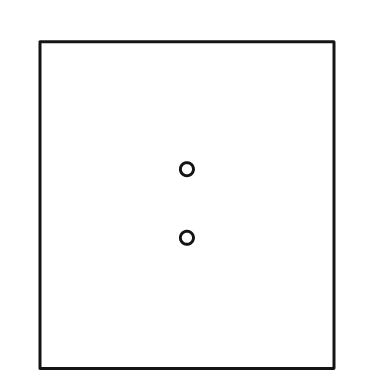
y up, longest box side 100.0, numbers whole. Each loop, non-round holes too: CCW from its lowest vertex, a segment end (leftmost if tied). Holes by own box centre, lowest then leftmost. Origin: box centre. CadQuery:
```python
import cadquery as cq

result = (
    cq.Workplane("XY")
    .moveTo(-45.0, -50.0)
    .lineTo(45.0, -50.0)
    .lineTo(45.0, 50.0)
    .lineTo(-45.0, 50.0)
    .close()
    .moveTo(0.0, -10.0)
    .circle(2.0)
    .moveTo(0.0, 11.0)
    .circle(2.0)
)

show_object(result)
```